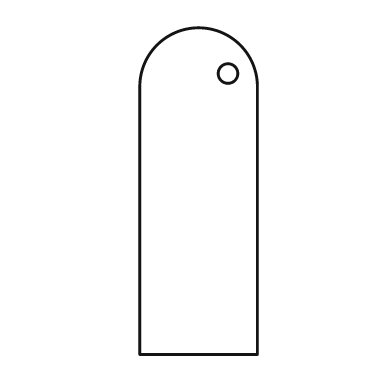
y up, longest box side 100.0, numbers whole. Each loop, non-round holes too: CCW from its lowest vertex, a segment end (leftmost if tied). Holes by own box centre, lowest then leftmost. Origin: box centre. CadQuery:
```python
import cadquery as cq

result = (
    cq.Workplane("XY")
    .moveTo(-18.0, -50.0)
    .lineTo(18.0, -50.0)
    .lineTo(18.0, 32.0)
    .threePointArc((0.0, 50.0), (-18.0, 32.0))
    .close()
    .moveTo(9.0, 36.0)
    .circle(3.0)
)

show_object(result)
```